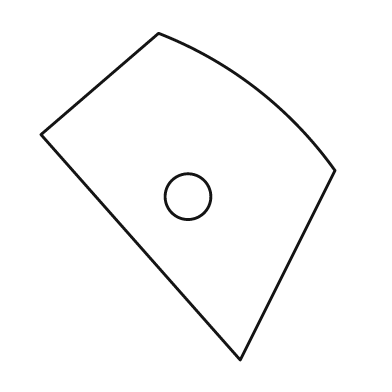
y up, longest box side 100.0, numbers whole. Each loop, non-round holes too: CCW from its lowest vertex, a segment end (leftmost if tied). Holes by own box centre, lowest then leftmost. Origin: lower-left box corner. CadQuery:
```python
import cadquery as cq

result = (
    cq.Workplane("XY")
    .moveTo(61.0, 0.0)
    .lineTo(90.0, 58.0)
    .threePointArc((66.0, 83.0), (36.0, 100.0))
    .lineTo(0.0, 69.0)
    .close()
    .moveTo(45.0, 50.0)
    .circle(7.0)
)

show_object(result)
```